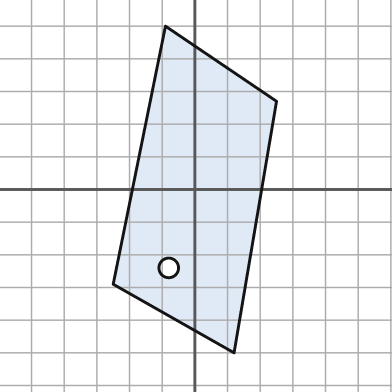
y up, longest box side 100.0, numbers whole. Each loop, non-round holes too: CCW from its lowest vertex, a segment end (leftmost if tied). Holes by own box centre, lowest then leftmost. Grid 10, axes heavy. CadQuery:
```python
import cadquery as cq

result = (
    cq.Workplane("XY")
    .moveTo(12.0, -50.0)
    .lineTo(25.0, 27.0)
    .lineTo(-9.0, 50.0)
    .lineTo(-25.0, -29.0)
    .close()
    .moveTo(-8.0, -24.0)
    .circle(3.0)
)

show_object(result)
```